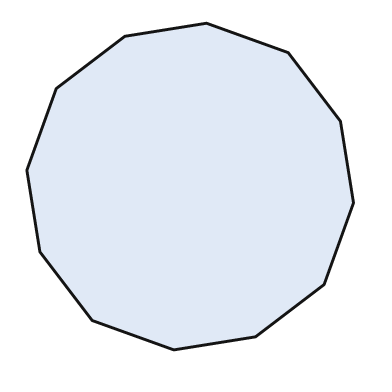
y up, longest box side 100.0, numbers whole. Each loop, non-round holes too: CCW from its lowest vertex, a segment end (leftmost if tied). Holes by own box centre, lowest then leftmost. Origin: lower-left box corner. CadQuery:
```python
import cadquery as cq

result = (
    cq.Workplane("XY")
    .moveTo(45.0, 0.0)
    .lineTo(70.0, 4.0)
    .lineTo(91.0, 20.0)
    .lineTo(100.0, 45.0)
    .lineTo(96.0, 70.0)
    .lineTo(80.0, 91.0)
    .lineTo(55.0, 100.0)
    .lineTo(30.0, 96.0)
    .lineTo(9.0, 80.0)
    .lineTo(0.0, 55.0)
    .lineTo(4.0, 30.0)
    .lineTo(20.0, 9.0)
    .close()
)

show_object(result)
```